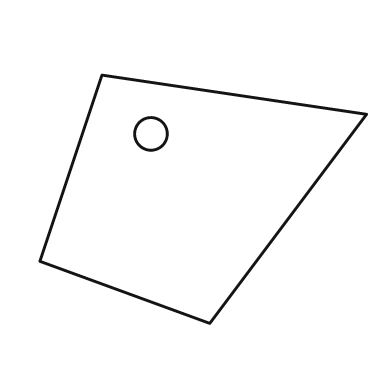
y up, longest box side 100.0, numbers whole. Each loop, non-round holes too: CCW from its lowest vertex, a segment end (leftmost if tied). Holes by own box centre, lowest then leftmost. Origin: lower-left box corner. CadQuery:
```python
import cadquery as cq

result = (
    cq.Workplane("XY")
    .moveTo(52.0, 0.0)
    .lineTo(100.0, 64.0)
    .lineTo(19.0, 76.0)
    .lineTo(0.0, 19.0)
    .close()
    .moveTo(34.0, 58.0)
    .circle(5.0)
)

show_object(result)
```